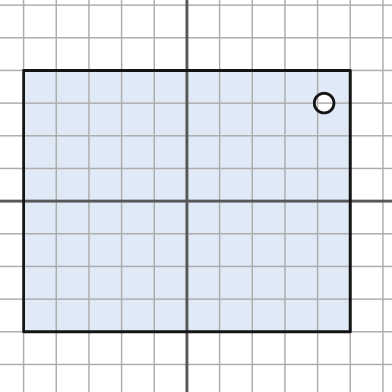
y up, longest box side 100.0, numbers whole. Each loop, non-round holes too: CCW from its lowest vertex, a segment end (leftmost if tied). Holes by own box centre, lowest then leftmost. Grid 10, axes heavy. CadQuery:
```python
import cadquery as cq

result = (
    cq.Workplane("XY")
    .moveTo(-50.0, -40.0)
    .lineTo(50.0, -40.0)
    .lineTo(50.0, 40.0)
    .lineTo(-50.0, 40.0)
    .close()
    .moveTo(42.0, 30.0)
    .circle(3.0)
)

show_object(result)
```